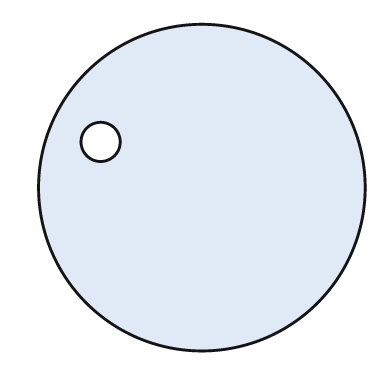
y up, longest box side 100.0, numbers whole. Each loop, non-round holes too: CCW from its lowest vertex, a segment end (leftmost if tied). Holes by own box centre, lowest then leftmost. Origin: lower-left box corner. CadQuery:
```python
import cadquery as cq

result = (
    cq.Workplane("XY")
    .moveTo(50.0, 50.0)
    .circle(50.0)
    .moveTo(19.0, 64.0)
    .circle(6.0)
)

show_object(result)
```